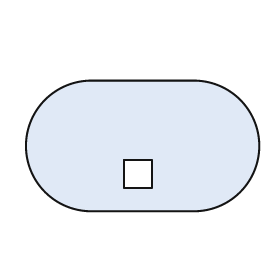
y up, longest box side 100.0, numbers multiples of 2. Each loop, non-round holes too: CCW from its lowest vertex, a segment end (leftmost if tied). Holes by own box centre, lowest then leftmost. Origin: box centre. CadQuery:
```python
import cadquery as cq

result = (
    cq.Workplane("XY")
    .moveTo(-22.0, -28.0)
    .lineTo(22.0, -28.0)
    .threePointArc((50.0, 0.0), (22.0, 28.0))
    .lineTo(-22.0, 28.0)
    .threePointArc((-50.0, 0.0), (-22.0, -28.0))
    .close()
    .moveTo(-8.0, -18.0)
    .lineTo(4.0, -18.0)
    .lineTo(4.0, -6.0)
    .lineTo(-8.0, -6.0)
    .close()
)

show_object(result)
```